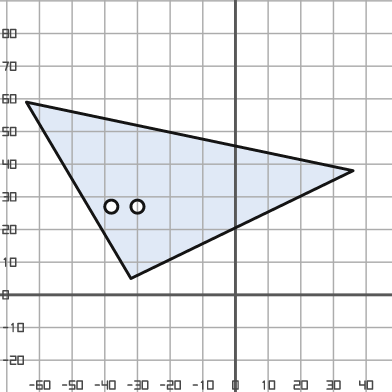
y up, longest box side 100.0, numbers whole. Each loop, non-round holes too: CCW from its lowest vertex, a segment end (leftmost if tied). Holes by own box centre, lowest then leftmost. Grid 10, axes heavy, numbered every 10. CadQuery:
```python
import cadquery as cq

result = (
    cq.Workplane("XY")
    .moveTo(-32.0, 5.0)
    .lineTo(36.0, 38.0)
    .lineTo(-64.0, 59.0)
    .close()
    .moveTo(-38.0, 27.0)
    .circle(2.0)
    .moveTo(-30.0, 27.0)
    .circle(2.0)
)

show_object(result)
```